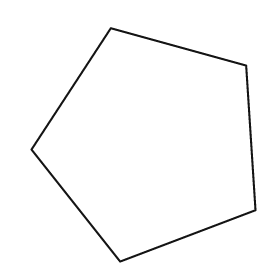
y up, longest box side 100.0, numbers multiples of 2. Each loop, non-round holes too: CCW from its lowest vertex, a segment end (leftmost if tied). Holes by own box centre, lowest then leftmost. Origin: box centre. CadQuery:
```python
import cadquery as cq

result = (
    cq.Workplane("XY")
    .moveTo(-10.0, -50.0)
    .lineTo(48.0, -28.0)
    .lineTo(44.0, 34.0)
    .lineTo(-14.0, 50.0)
    .lineTo(-48.0, -2.0)
    .close()
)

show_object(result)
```